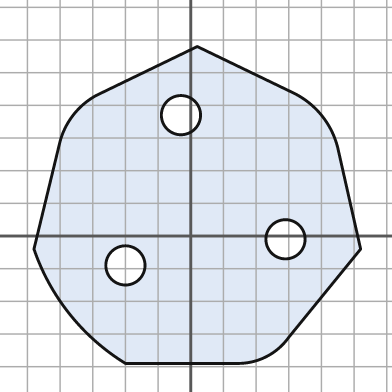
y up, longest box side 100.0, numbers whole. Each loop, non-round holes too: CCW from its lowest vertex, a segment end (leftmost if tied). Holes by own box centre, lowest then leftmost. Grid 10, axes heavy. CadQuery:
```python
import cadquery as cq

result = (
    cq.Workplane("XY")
    .moveTo(-20.0, -39.0)
    .lineTo(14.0, -39.0)
    .threePointArc((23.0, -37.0), (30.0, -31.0))
    .lineTo(52.0, -4.0)
    .lineTo(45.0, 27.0)
    .threePointArc((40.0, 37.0), (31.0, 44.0))
    .lineTo(2.0, 58.0)
    .lineTo(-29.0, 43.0)
    .threePointArc((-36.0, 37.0), (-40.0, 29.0))
    .lineTo(-48.0, -4.0)
    .threePointArc((-37.0, -24.0), (-20.0, -39.0))
    .close()
    .moveTo(-20.0, -9.0)
    .circle(6.0)
    .moveTo(29.0, -1.0)
    .circle(6.0)
    .moveTo(-3.0, 37.0)
    .circle(6.0)
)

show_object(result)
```